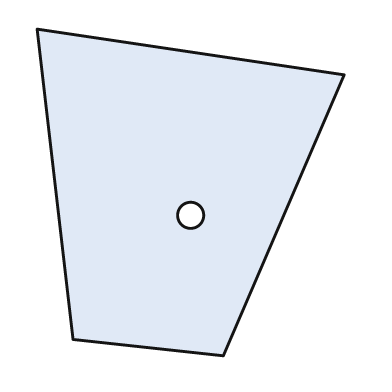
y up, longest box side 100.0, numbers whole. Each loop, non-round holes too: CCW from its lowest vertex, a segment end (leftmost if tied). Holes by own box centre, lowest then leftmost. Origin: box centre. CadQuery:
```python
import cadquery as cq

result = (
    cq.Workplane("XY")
    .moveTo(10.0, -50.0)
    .lineTo(47.0, 36.0)
    .lineTo(-47.0, 50.0)
    .lineTo(-36.0, -45.0)
    .close()
    .moveTo(0.0, -7.0)
    .circle(4.0)
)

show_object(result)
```